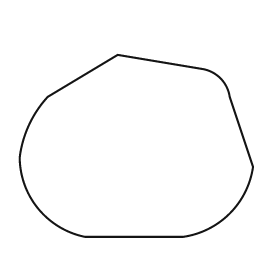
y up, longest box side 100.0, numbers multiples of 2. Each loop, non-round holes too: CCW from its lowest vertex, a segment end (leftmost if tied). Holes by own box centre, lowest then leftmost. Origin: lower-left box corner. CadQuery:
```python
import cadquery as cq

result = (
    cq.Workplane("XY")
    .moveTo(28.0, 0.0)
    .lineTo(70.0, 0.0)
    .threePointArc((90.0, 10.0), (100.0, 30.0))
    .lineTo(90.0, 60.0)
    .threePointArc((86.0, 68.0), (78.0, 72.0))
    .lineTo(42.0, 78.0)
    .lineTo(12.0, 60.0)
    .threePointArc((4.0, 48.0), (0.0, 34.0))
    .threePointArc((8.0, 12.0), (28.0, 0.0))
    .close()
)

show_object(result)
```